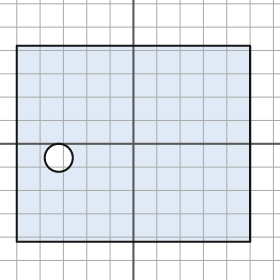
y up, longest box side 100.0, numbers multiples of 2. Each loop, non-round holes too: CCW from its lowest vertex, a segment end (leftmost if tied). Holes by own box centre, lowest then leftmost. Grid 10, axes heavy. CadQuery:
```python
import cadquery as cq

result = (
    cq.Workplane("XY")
    .moveTo(-50.0, -42.0)
    .lineTo(50.0, -42.0)
    .lineTo(50.0, 42.0)
    .lineTo(-50.0, 42.0)
    .close()
    .moveTo(-32.0, -6.0)
    .circle(6.0)
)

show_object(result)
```